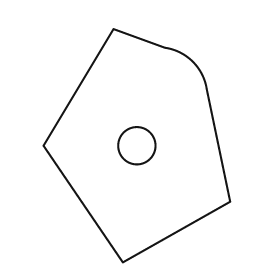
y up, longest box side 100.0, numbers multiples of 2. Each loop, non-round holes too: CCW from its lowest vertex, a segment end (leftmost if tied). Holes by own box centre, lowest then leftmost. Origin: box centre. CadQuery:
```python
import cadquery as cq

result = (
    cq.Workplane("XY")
    .moveTo(-6.0, -50.0)
    .lineTo(40.0, -24.0)
    .lineTo(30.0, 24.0)
    .threePointArc((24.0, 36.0), (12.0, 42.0))
    .lineTo(-10.0, 50.0)
    .lineTo(-40.0, 0.0)
    .close()
    .moveTo(0.0, 0.0)
    .circle(8.0)
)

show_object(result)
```